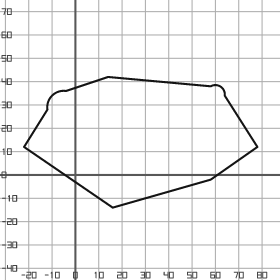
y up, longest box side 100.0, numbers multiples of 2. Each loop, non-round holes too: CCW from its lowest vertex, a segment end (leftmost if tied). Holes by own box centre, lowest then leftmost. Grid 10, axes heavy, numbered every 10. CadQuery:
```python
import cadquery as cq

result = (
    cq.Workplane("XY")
    .moveTo(16.0, -14.0)
    .lineTo(58.0, -2.0)
    .lineTo(78.0, 12.0)
    .lineTo(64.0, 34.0)
    .threePointArc((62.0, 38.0), (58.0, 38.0))
    .lineTo(14.0, 42.0)
    .lineTo(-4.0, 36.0)
    .threePointArc((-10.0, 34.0), (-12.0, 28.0))
    .lineTo(-22.0, 12.0)
    .close()
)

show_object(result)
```